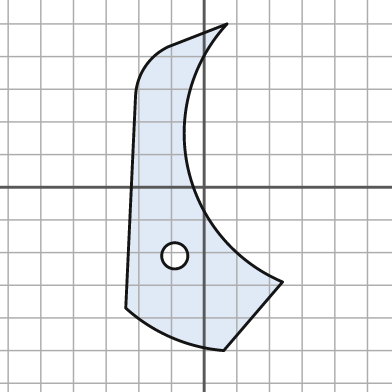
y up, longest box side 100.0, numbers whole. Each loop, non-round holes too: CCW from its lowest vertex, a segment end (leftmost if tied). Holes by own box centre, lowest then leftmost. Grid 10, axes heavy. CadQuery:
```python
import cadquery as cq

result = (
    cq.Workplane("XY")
    .moveTo(6.0, -50.0)
    .lineTo(24.0, -29.0)
    .threePointArc((-5.0, 6.0), (7.0, 50.0))
    .lineTo(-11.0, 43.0)
    .threePointArc((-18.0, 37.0), (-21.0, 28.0))
    .lineTo(-24.0, -37.0)
    .threePointArc((-10.0, -46.0), (6.0, -50.0))
    .close()
    .moveTo(-9.0, -21.0)
    .circle(4.0)
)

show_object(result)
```